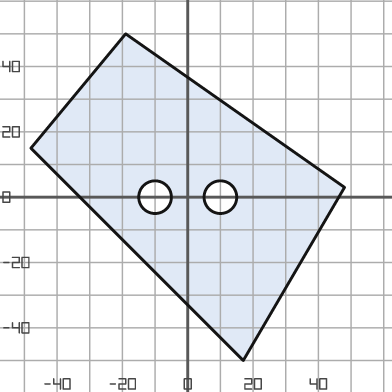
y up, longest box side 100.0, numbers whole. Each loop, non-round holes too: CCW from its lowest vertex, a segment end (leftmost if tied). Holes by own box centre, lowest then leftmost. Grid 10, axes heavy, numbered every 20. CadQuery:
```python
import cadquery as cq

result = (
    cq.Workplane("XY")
    .moveTo(17.0, -50.0)
    .lineTo(48.0, 3.0)
    .lineTo(-19.0, 50.0)
    .lineTo(-48.0, 15.0)
    .close()
    .moveTo(-10.0, 0.0)
    .circle(5.0)
    .moveTo(10.0, 0.0)
    .circle(5.0)
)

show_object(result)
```